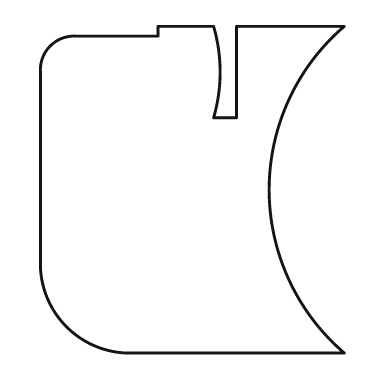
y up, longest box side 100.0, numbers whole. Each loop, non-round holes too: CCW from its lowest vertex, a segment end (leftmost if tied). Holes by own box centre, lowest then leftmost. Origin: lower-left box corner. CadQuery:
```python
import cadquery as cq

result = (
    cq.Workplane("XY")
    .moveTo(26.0, 0.0)
    .lineTo(93.0, 0.0)
    .threePointArc((70.0, 50.0), (93.0, 100.0))
    .lineTo(60.0, 100.0)
    .lineTo(60.0, 72.0)
    .lineTo(53.0, 72.0)
    .threePointArc((55.0, 86.0), (53.0, 100.0))
    .lineTo(36.0, 100.0)
    .lineTo(36.0, 97.0)
    .lineTo(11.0, 97.0)
    .threePointArc((3.0, 94.0), (0.0, 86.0))
    .lineTo(0.0, 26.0)
    .threePointArc((8.0, 8.0), (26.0, 0.0))
    .close()
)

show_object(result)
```